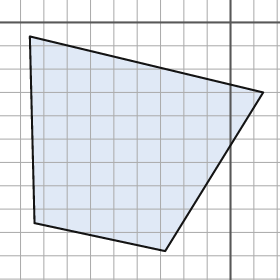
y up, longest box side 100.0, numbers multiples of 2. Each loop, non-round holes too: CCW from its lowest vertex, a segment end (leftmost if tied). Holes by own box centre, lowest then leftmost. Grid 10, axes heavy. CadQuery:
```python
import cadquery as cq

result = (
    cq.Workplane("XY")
    .moveTo(-28.0, -98.0)
    .lineTo(14.0, -30.0)
    .lineTo(-86.0, -6.0)
    .lineTo(-84.0, -86.0)
    .close()
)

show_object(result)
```